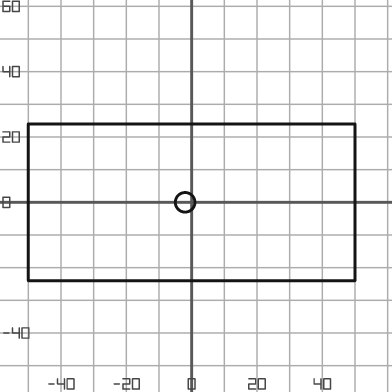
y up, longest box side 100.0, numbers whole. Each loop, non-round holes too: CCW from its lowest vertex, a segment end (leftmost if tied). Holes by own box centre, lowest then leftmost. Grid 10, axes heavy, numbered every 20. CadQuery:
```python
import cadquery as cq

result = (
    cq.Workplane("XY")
    .moveTo(-50.0, -24.0)
    .lineTo(50.0, -24.0)
    .lineTo(50.0, 24.0)
    .lineTo(-50.0, 24.0)
    .close()
    .moveTo(-2.0, 0.0)
    .circle(3.0)
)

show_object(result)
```